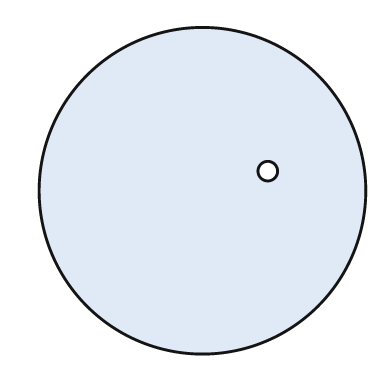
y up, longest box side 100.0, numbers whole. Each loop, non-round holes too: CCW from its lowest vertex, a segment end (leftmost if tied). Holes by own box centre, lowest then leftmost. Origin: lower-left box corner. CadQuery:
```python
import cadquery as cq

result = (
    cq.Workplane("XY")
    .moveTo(50.0, 50.0)
    .circle(50.0)
    .moveTo(70.0, 56.0)
    .circle(3.0)
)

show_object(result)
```